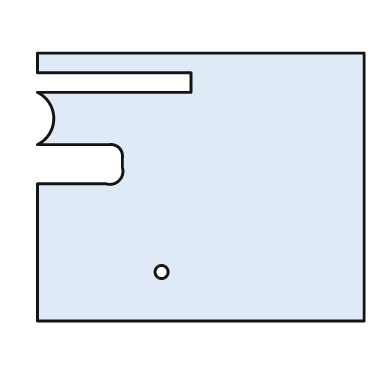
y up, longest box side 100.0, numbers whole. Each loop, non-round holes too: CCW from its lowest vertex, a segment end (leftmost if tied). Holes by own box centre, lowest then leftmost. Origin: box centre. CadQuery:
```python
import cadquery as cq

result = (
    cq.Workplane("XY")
    .moveTo(-50.0, -41.0)
    .lineTo(50.0, -41.0)
    .lineTo(50.0, 41.0)
    .lineTo(-50.0, 41.0)
    .lineTo(-50.0, 35.0)
    .lineTo(-3.0, 35.0)
    .lineTo(-3.0, 29.0)
    .lineTo(-50.0, 29.0)
    .threePointArc((-45.0, 21.0), (-50.0, 13.0))
    .lineTo(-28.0, 13.0)
    .threePointArc((-25.0, 12.0), (-24.0, 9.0))
    .lineTo(-24.0, 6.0)
    .threePointArc((-25.0, 2.0), (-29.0, 1.0))
    .lineTo(-50.0, 1.0)
    .close()
    .moveTo(-12.0, -26.0)
    .circle(2.0)
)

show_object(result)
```